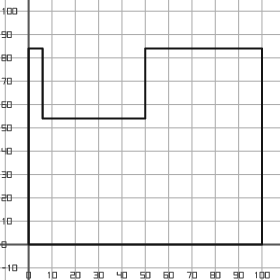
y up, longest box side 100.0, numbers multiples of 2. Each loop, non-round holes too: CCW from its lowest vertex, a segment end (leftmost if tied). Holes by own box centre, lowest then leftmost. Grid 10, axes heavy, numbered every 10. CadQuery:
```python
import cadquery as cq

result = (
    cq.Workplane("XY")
    .moveTo(0.0, 0.0)
    .lineTo(100.0, 0.0)
    .lineTo(100.0, 84.0)
    .lineTo(50.0, 84.0)
    .lineTo(50.0, 54.0)
    .lineTo(6.0, 54.0)
    .lineTo(6.0, 84.0)
    .lineTo(0.0, 84.0)
    .close()
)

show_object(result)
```